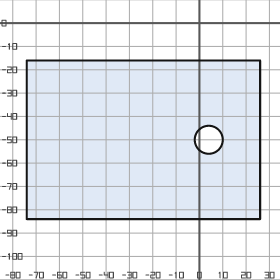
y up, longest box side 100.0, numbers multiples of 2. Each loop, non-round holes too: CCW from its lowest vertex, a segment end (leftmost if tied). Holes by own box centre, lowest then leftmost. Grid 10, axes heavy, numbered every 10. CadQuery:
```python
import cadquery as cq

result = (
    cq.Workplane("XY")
    .moveTo(-74.0, -84.0)
    .lineTo(26.0, -84.0)
    .lineTo(26.0, -16.0)
    .lineTo(-74.0, -16.0)
    .close()
    .moveTo(4.0, -50.0)
    .circle(6.0)
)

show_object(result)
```